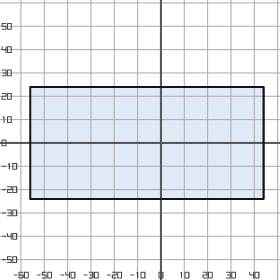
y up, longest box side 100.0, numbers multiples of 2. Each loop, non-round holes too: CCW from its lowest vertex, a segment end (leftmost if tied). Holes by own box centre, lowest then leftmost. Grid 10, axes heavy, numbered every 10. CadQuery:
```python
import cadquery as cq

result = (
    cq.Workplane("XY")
    .moveTo(-56.0, -24.0)
    .lineTo(44.0, -24.0)
    .lineTo(44.0, 24.0)
    .lineTo(-56.0, 24.0)
    .close()
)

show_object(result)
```